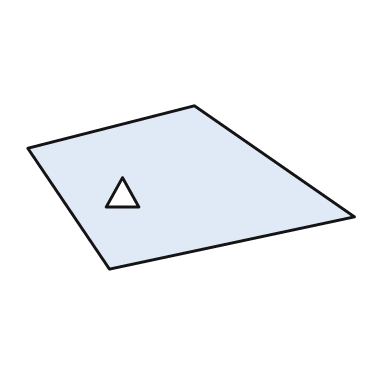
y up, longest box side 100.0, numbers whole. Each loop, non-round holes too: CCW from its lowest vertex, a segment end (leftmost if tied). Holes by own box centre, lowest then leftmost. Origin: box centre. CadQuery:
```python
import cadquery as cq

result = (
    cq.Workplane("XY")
    .moveTo(-25.0, -25.0)
    .lineTo(50.0, -9.0)
    .lineTo(1.0, 25.0)
    .lineTo(-50.0, 12.0)
    .close()
    .moveTo(-26.0, -6.0)
    .lineTo(-16.0, -6.0)
    .lineTo(-21.0, 3.0)
    .close()
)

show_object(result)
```